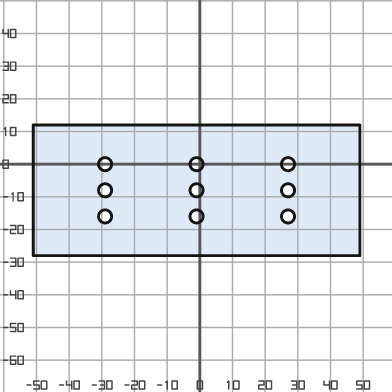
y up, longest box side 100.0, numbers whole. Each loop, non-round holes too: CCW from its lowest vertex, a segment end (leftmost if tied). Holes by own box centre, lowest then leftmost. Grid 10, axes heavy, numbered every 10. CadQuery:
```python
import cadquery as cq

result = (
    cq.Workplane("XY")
    .moveTo(-51.0, -28.0)
    .lineTo(49.0, -28.0)
    .lineTo(49.0, 12.0)
    .lineTo(-51.0, 12.0)
    .close()
    .moveTo(-29.0, -16.0)
    .circle(2.0)
    .moveTo(-1.0, -16.0)
    .circle(2.0)
    .moveTo(27.0, -16.0)
    .circle(2.0)
    .moveTo(-29.0, -8.0)
    .circle(2.0)
    .moveTo(-1.0, -8.0)
    .circle(2.0)
    .moveTo(27.0, -8.0)
    .circle(2.0)
    .moveTo(-29.0, 0.0)
    .circle(2.0)
    .moveTo(-1.0, 0.0)
    .circle(2.0)
    .moveTo(27.0, 0.0)
    .circle(2.0)
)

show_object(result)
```